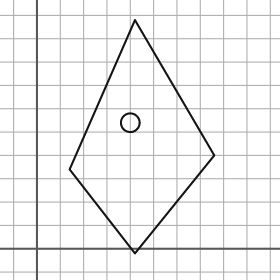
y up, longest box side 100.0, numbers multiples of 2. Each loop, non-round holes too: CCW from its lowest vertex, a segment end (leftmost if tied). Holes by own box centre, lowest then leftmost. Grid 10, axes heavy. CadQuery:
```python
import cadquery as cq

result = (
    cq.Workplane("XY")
    .moveTo(42.0, -2.0)
    .lineTo(76.0, 40.0)
    .lineTo(42.0, 98.0)
    .lineTo(14.0, 34.0)
    .close()
    .moveTo(40.0, 54.0)
    .circle(4.0)
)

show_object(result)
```